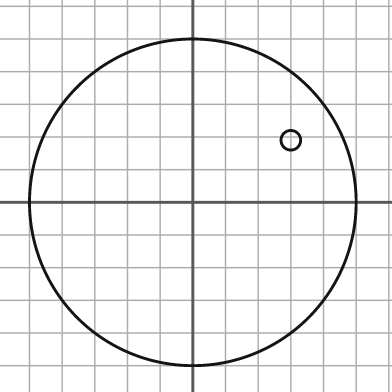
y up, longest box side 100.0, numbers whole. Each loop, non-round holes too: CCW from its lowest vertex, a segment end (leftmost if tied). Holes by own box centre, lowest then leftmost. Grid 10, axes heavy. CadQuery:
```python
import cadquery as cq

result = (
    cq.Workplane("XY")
    .moveTo(0.0, 0.0)
    .circle(50.0)
    .moveTo(30.0, 19.0)
    .circle(3.0)
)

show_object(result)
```